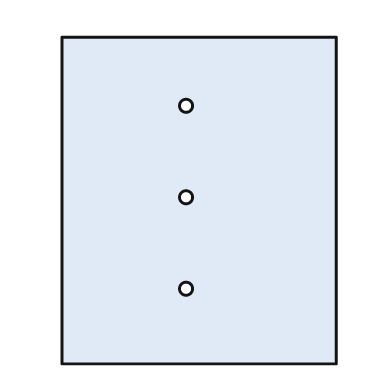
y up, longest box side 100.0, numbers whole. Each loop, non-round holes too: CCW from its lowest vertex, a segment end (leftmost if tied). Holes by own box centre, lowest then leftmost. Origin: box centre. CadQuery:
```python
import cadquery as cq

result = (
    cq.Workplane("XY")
    .moveTo(-42.0, -50.0)
    .lineTo(42.0, -50.0)
    .lineTo(42.0, 50.0)
    .lineTo(-42.0, 50.0)
    .close()
    .moveTo(-4.0, -27.0)
    .circle(2.0)
    .moveTo(-4.0, 1.0)
    .circle(2.0)
    .moveTo(-4.0, 29.0)
    .circle(2.0)
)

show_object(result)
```